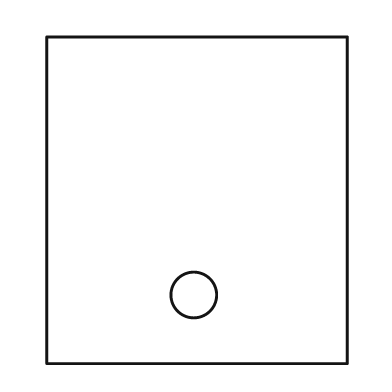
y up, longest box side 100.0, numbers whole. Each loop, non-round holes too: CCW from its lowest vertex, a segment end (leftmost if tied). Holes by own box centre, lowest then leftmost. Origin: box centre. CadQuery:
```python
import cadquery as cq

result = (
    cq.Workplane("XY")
    .moveTo(-46.0, -50.0)
    .lineTo(46.0, -50.0)
    .lineTo(46.0, 50.0)
    .lineTo(-46.0, 50.0)
    .close()
    .moveTo(-1.0, -29.0)
    .circle(7.0)
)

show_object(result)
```